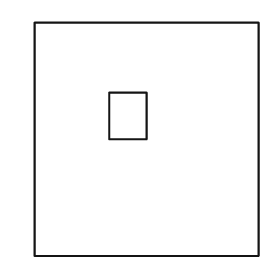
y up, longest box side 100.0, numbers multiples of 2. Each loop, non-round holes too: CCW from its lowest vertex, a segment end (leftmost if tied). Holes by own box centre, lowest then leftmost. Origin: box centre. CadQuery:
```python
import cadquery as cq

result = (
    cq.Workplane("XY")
    .moveTo(-48.0, -50.0)
    .lineTo(48.0, -50.0)
    .lineTo(48.0, 50.0)
    .lineTo(-48.0, 50.0)
    .close()
    .moveTo(-16.0, 0.0)
    .lineTo(0.0, 0.0)
    .lineTo(0.0, 20.0)
    .lineTo(-16.0, 20.0)
    .close()
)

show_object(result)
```